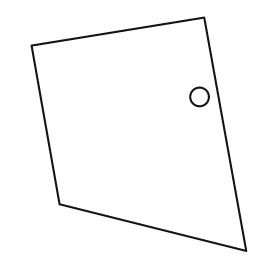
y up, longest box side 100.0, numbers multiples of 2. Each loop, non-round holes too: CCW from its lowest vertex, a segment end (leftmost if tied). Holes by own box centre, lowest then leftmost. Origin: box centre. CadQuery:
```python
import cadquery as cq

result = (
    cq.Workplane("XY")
    .moveTo(46.0, -50.0)
    .lineTo(28.0, 50.0)
    .lineTo(-46.0, 38.0)
    .lineTo(-34.0, -30.0)
    .close()
    .moveTo(26.0, 16.0)
    .circle(4.0)
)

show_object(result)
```